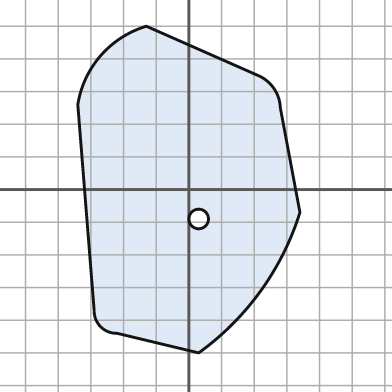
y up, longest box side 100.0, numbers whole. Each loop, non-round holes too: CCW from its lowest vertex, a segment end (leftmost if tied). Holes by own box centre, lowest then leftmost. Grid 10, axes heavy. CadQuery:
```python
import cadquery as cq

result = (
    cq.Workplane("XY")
    .moveTo(3.0, -50.0)
    .threePointArc((22.0, -31.0), (34.0, -7.0))
    .lineTo(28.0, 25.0)
    .threePointArc((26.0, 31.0), (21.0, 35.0))
    .lineTo(-13.0, 50.0)
    .threePointArc((-27.0, 41.0), (-34.0, 26.0))
    .lineTo(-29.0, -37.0)
    .threePointArc((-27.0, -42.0), (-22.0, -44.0))
    .close()
    .moveTo(3.0, -9.0)
    .circle(3.0)
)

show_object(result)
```